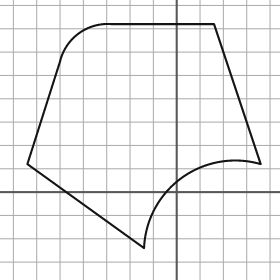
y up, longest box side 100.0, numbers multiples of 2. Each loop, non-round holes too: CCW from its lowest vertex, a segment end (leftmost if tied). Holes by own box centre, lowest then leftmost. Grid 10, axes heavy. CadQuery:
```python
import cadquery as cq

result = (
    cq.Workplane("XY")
    .moveTo(-14.0, -24.0)
    .threePointArc((2.0, 6.0), (36.0, 12.0))
    .lineTo(16.0, 72.0)
    .lineTo(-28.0, 72.0)
    .threePointArc((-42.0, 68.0), (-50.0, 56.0))
    .lineTo(-64.0, 12.0)
    .close()
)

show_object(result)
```